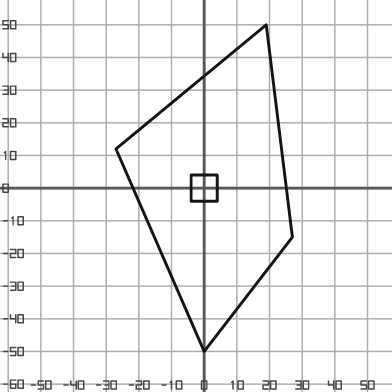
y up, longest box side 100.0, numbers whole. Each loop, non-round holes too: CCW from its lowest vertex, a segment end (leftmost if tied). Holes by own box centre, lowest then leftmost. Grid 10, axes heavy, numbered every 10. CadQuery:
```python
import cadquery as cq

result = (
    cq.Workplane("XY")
    .moveTo(0.0, -50.0)
    .lineTo(27.0, -15.0)
    .lineTo(19.0, 50.0)
    .lineTo(-27.0, 12.0)
    .close()
    .moveTo(-4.0, -4.0)
    .lineTo(4.0, -4.0)
    .lineTo(4.0, 4.0)
    .lineTo(-4.0, 4.0)
    .close()
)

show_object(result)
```